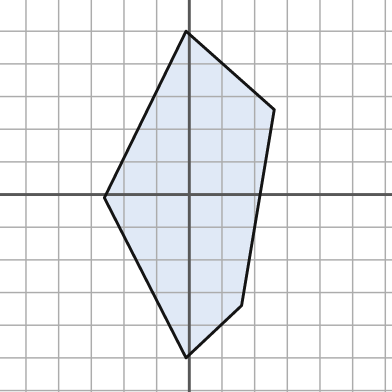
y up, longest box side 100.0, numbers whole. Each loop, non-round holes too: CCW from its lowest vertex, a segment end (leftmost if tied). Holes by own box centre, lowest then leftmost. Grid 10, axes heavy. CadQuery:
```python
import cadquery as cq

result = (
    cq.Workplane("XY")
    .moveTo(-1.0, -50.0)
    .lineTo(16.0, -34.0)
    .lineTo(26.0, 26.0)
    .lineTo(-1.0, 50.0)
    .lineTo(-26.0, -1.0)
    .close()
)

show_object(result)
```